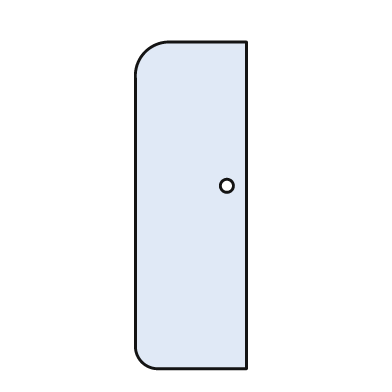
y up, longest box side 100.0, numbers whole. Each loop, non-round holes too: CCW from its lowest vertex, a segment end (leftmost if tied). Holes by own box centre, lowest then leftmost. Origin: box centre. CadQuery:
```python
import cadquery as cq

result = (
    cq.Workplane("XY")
    .moveTo(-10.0, -50.0)
    .lineTo(17.0, -50.0)
    .lineTo(17.0, 50.0)
    .lineTo(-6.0, 50.0)
    .threePointArc((-14.0, 47.0), (-17.0, 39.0))
    .lineTo(-17.0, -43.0)
    .threePointArc((-15.0, -48.0), (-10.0, -50.0))
    .close()
    .moveTo(11.0, 6.0)
    .circle(2.0)
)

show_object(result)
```